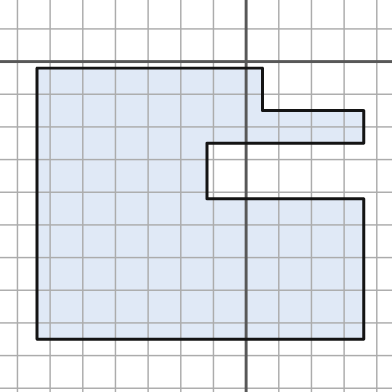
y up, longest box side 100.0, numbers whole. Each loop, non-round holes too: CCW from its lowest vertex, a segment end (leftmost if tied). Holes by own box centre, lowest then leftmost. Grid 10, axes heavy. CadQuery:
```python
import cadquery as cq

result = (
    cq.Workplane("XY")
    .moveTo(-64.0, -85.0)
    .lineTo(36.0, -85.0)
    .lineTo(36.0, -42.0)
    .lineTo(-12.0, -42.0)
    .lineTo(-12.0, -25.0)
    .lineTo(36.0, -25.0)
    .lineTo(36.0, -15.0)
    .lineTo(5.0, -15.0)
    .lineTo(5.0, -2.0)
    .lineTo(-64.0, -2.0)
    .close()
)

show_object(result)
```